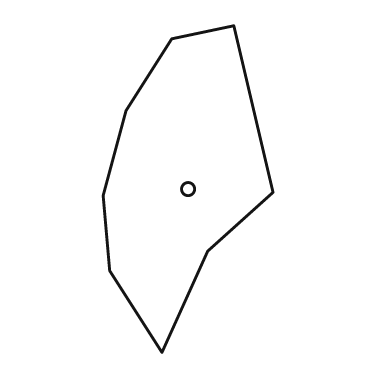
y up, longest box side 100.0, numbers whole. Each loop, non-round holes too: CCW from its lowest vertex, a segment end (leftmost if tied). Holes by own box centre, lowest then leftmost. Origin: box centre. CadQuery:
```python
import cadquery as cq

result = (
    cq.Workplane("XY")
    .moveTo(-8.0, -50.0)
    .lineTo(6.0, -19.0)
    .lineTo(26.0, -1.0)
    .lineTo(14.0, 50.0)
    .lineTo(-5.0, 46.0)
    .lineTo(-19.0, 24.0)
    .lineTo(-26.0, -2.0)
    .lineTo(-24.0, -25.0)
    .close()
    .moveTo(0.0, 0.0)
    .circle(2.0)
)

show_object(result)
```